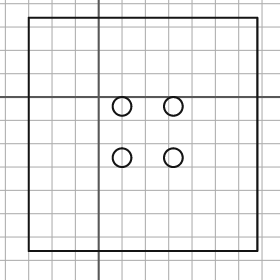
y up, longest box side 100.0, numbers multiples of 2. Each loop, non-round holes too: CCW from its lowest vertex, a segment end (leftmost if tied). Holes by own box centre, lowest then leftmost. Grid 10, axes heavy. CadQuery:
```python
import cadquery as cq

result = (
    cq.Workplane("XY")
    .moveTo(-30.0, -66.0)
    .lineTo(68.0, -66.0)
    .lineTo(68.0, 34.0)
    .lineTo(-30.0, 34.0)
    .close()
    .moveTo(10.0, -26.0)
    .circle(4.0)
    .moveTo(32.0, -26.0)
    .circle(4.0)
    .moveTo(10.0, -4.0)
    .circle(4.0)
    .moveTo(32.0, -4.0)
    .circle(4.0)
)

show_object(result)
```